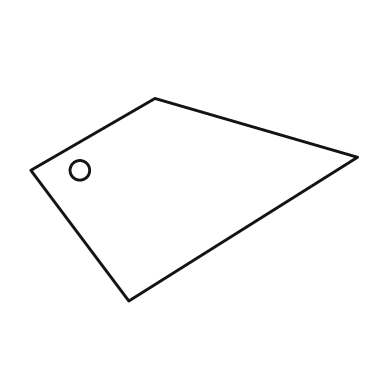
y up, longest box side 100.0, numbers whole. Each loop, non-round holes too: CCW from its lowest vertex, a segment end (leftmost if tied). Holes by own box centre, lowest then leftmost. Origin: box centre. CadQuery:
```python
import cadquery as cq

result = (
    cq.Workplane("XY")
    .moveTo(-20.0, -31.0)
    .lineTo(50.0, 13.0)
    .lineTo(-12.0, 31.0)
    .lineTo(-50.0, 9.0)
    .close()
    .moveTo(-35.0, 9.0)
    .circle(3.0)
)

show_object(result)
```